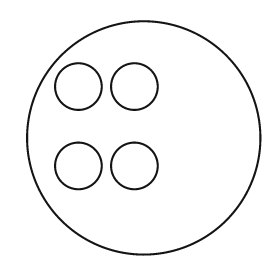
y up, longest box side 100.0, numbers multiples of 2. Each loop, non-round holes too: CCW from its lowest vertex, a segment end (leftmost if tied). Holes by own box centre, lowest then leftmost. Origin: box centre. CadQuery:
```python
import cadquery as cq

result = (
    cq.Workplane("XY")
    .moveTo(0.0, 0.0)
    .circle(50.0)
    .moveTo(-28.0, -12.0)
    .circle(10.0)
    .moveTo(-4.0, -12.0)
    .circle(10.0)
    .moveTo(-28.0, 22.0)
    .circle(10.0)
    .moveTo(-4.0, 22.0)
    .circle(10.0)
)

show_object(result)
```